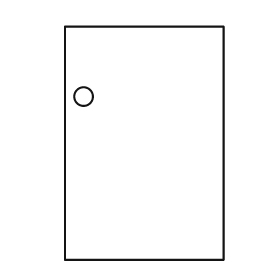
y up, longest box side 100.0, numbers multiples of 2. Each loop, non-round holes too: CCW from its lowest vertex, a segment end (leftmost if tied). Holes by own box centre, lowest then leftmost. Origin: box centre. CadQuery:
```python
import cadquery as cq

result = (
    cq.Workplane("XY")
    .moveTo(-34.0, -50.0)
    .lineTo(34.0, -50.0)
    .lineTo(34.0, 50.0)
    .lineTo(-34.0, 50.0)
    .close()
    .moveTo(-26.0, 20.0)
    .circle(4.0)
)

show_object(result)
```